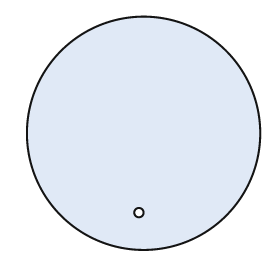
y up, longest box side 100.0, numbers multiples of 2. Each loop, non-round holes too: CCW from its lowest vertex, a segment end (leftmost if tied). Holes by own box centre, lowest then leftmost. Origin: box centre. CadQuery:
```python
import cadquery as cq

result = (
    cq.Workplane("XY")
    .moveTo(0.0, 0.0)
    .circle(50.0)
    .moveTo(-2.0, -34.0)
    .circle(2.0)
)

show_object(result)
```